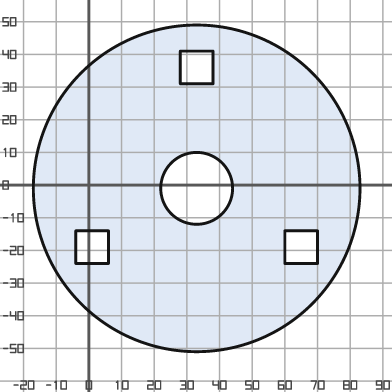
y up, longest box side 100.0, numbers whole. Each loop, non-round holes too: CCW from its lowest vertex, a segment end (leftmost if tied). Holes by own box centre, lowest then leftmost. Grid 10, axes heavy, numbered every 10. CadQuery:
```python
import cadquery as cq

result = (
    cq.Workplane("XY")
    .moveTo(33.0, -1.0)
    .circle(50.0)
    .moveTo(-4.0, -24.0)
    .lineTo(6.0, -24.0)
    .lineTo(6.0, -14.0)
    .lineTo(-4.0, -14.0)
    .close()
    .moveTo(60.0, -24.0)
    .lineTo(70.0, -24.0)
    .lineTo(70.0, -14.0)
    .lineTo(60.0, -14.0)
    .close()
    .moveTo(33.0, -1.0)
    .circle(11.0)
    .moveTo(28.0, 31.0)
    .lineTo(38.0, 31.0)
    .lineTo(38.0, 41.0)
    .lineTo(28.0, 41.0)
    .close()
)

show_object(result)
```